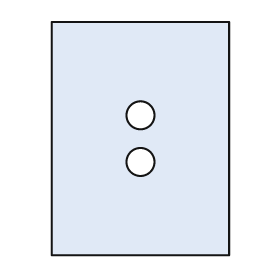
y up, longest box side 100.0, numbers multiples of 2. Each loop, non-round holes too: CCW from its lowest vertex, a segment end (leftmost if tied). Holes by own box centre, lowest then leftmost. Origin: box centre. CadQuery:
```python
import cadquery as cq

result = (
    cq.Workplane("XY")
    .moveTo(-38.0, -50.0)
    .lineTo(38.0, -50.0)
    .lineTo(38.0, 50.0)
    .lineTo(-38.0, 50.0)
    .close()
    .moveTo(0.0, -10.0)
    .circle(6.0)
    .moveTo(0.0, 10.0)
    .circle(6.0)
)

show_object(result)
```